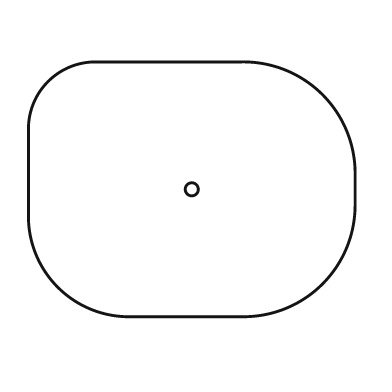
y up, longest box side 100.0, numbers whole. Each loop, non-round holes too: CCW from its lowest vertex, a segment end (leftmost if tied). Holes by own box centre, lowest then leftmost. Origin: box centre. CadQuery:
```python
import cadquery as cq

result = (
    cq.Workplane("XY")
    .moveTo(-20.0, -39.0)
    .lineTo(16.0, -39.0)
    .threePointArc((40.0, -29.0), (50.0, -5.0))
    .lineTo(50.0, 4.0)
    .threePointArc((40.0, 29.0), (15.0, 39.0))
    .lineTo(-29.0, 39.0)
    .threePointArc((-44.0, 33.0), (-50.0, 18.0))
    .lineTo(-50.0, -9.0)
    .threePointArc((-41.0, -30.0), (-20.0, -39.0))
    .close()
    .moveTo(0.0, 0.0)
    .circle(2.0)
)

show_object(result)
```